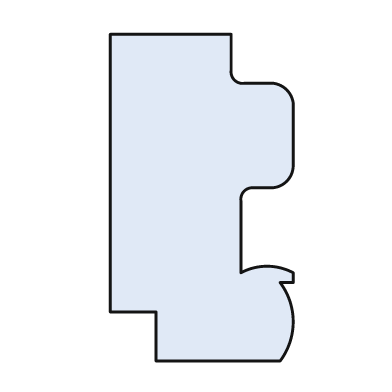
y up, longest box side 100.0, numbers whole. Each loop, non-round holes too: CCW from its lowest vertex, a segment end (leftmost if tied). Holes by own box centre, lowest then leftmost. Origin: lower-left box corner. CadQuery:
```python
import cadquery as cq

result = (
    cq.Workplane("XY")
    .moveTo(14.0, 0.0)
    .lineTo(52.0, 0.0)
    .threePointArc((56.0, 12.0), (52.0, 24.0))
    .lineTo(56.0, 24.0)
    .lineTo(56.0, 27.0)
    .threePointArc((48.0, 29.0), (40.0, 27.0))
    .lineTo(40.0, 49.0)
    .threePointArc((41.0, 52.0), (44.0, 53.0))
    .lineTo(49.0, 53.0)
    .threePointArc((54.0, 55.0), (56.0, 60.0))
    .lineTo(56.0, 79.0)
    .threePointArc((54.0, 83.0), (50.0, 85.0))
    .lineTo(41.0, 85.0)
    .threePointArc((38.0, 86.0), (37.0, 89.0))
    .lineTo(37.0, 100.0)
    .lineTo(0.0, 100.0)
    .lineTo(0.0, 15.0)
    .lineTo(14.0, 15.0)
    .close()
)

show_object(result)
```